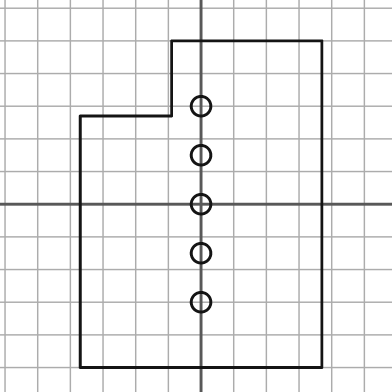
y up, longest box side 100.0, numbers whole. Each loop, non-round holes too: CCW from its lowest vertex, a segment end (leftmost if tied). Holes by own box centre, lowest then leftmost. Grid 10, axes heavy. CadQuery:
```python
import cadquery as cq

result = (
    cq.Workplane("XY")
    .moveTo(-37.0, -50.0)
    .lineTo(37.0, -50.0)
    .lineTo(37.0, 50.0)
    .lineTo(-9.0, 50.0)
    .lineTo(-9.0, 27.0)
    .lineTo(-37.0, 27.0)
    .close()
    .moveTo(0.0, -30.0)
    .circle(3.0)
    .moveTo(0.0, -15.0)
    .circle(3.0)
    .moveTo(0.0, 0.0)
    .circle(3.0)
    .moveTo(0.0, 15.0)
    .circle(3.0)
    .moveTo(0.0, 30.0)
    .circle(3.0)
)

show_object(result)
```